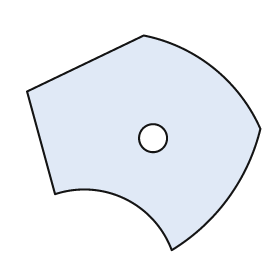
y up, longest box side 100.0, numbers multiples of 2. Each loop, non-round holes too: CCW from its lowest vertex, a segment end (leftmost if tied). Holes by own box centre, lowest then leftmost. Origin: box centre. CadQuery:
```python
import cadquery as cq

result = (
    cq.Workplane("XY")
    .moveTo(12.0, -46.0)
    .threePointArc((36.0, -24.0), (50.0, 6.0))
    .threePointArc((30.0, 32.0), (0.0, 46.0))
    .lineTo(-50.0, 22.0)
    .lineTo(-38.0, -22.0)
    .threePointArc((-8.0, -24.0), (12.0, -46.0))
    .close()
    .moveTo(4.0, 2.0)
    .circle(6.0)
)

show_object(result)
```